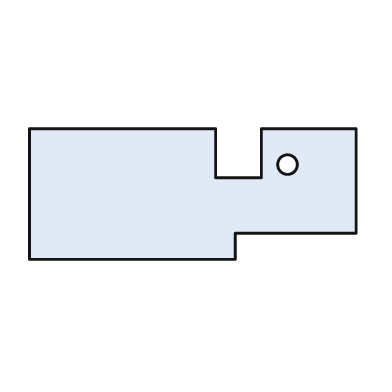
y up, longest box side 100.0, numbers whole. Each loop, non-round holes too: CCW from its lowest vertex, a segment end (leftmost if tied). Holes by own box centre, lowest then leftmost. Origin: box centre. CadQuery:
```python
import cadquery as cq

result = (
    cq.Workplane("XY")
    .moveTo(-50.0, -20.0)
    .lineTo(13.0, -20.0)
    .lineTo(13.0, -12.0)
    .lineTo(50.0, -12.0)
    .lineTo(50.0, 20.0)
    .lineTo(21.0, 20.0)
    .lineTo(21.0, 5.0)
    .lineTo(7.0, 5.0)
    .lineTo(7.0, 20.0)
    .lineTo(-50.0, 20.0)
    .close()
    .moveTo(29.0, 9.0)
    .circle(3.0)
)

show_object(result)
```